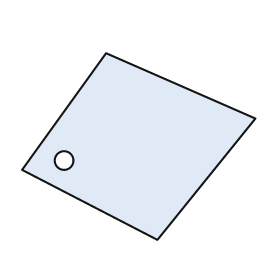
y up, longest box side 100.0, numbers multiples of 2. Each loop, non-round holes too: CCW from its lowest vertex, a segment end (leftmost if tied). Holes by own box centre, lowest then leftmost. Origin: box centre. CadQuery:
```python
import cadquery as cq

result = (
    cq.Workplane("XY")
    .moveTo(8.0, -40.0)
    .lineTo(50.0, 12.0)
    .lineTo(-14.0, 40.0)
    .lineTo(-50.0, -10.0)
    .close()
    .moveTo(-32.0, -6.0)
    .circle(4.0)
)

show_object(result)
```